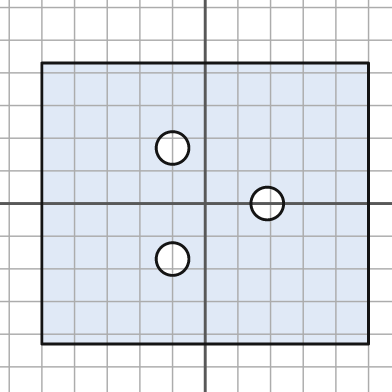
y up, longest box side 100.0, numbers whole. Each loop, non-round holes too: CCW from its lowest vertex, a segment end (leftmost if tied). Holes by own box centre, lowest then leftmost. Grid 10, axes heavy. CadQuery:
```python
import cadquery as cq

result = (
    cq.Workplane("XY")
    .moveTo(-50.0, -43.0)
    .lineTo(50.0, -43.0)
    .lineTo(50.0, 43.0)
    .lineTo(-50.0, 43.0)
    .close()
    .moveTo(-10.0, -17.0)
    .circle(5.0)
    .moveTo(19.0, 0.0)
    .circle(5.0)
    .moveTo(-10.0, 17.0)
    .circle(5.0)
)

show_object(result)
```